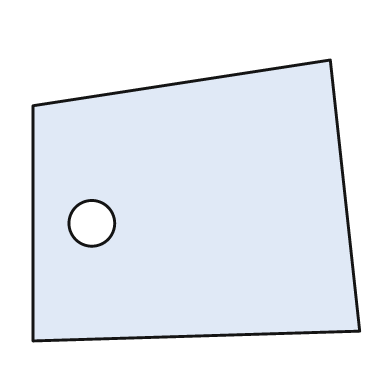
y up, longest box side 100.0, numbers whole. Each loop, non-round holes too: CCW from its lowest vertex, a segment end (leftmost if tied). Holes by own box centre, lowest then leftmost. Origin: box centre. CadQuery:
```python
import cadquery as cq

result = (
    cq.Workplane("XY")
    .moveTo(-50.0, -43.0)
    .lineTo(50.0, -40.0)
    .lineTo(41.0, 43.0)
    .lineTo(-50.0, 29.0)
    .close()
    .moveTo(-32.0, -7.0)
    .circle(7.0)
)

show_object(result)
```